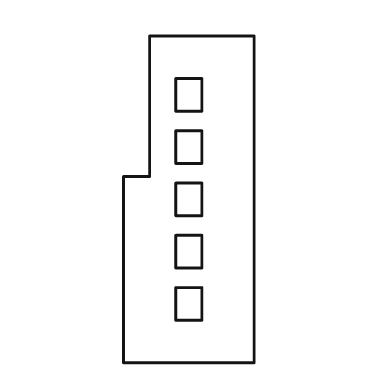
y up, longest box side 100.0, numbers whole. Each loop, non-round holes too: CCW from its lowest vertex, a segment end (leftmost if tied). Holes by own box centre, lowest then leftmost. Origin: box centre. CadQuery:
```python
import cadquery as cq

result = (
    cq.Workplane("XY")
    .moveTo(-20.0, -50.0)
    .lineTo(20.0, -50.0)
    .lineTo(20.0, 50.0)
    .lineTo(-12.0, 50.0)
    .lineTo(-12.0, 7.0)
    .lineTo(-20.0, 7.0)
    .close()
    .moveTo(-4.0, -37.0)
    .lineTo(4.0, -37.0)
    .lineTo(4.0, -27.0)
    .lineTo(-4.0, -27.0)
    .close()
    .moveTo(-4.0, -21.0)
    .lineTo(4.0, -21.0)
    .lineTo(4.0, -11.0)
    .lineTo(-4.0, -11.0)
    .close()
    .moveTo(-4.0, -5.0)
    .lineTo(4.0, -5.0)
    .lineTo(4.0, 5.0)
    .lineTo(-4.0, 5.0)
    .close()
    .moveTo(-4.0, 11.0)
    .lineTo(4.0, 11.0)
    .lineTo(4.0, 21.0)
    .lineTo(-4.0, 21.0)
    .close()
    .moveTo(-4.0, 27.0)
    .lineTo(4.0, 27.0)
    .lineTo(4.0, 37.0)
    .lineTo(-4.0, 37.0)
    .close()
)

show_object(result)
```